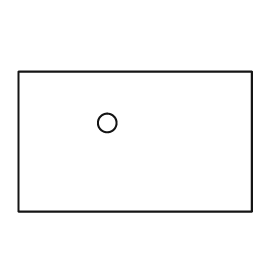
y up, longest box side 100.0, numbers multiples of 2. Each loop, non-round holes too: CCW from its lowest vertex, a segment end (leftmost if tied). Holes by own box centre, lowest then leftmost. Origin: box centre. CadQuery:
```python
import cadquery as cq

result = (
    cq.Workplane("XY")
    .moveTo(-50.0, -30.0)
    .lineTo(50.0, -30.0)
    .lineTo(50.0, 30.0)
    .lineTo(-50.0, 30.0)
    .close()
    .moveTo(-12.0, 8.0)
    .circle(4.0)
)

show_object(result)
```